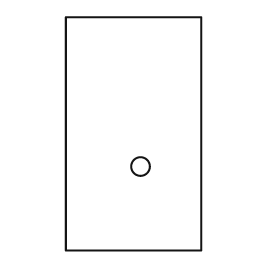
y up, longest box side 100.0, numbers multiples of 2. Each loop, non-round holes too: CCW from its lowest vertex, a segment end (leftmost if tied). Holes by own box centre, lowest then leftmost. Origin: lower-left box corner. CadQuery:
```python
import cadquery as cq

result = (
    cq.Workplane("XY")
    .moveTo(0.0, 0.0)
    .lineTo(58.0, 0.0)
    .lineTo(58.0, 100.0)
    .lineTo(0.0, 100.0)
    .close()
    .moveTo(32.0, 36.0)
    .circle(4.0)
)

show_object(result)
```